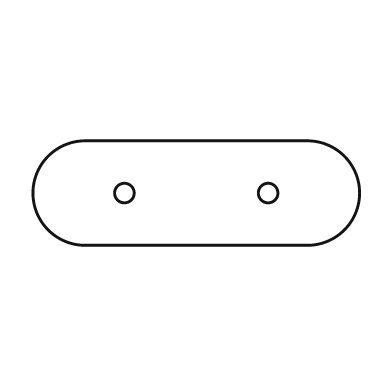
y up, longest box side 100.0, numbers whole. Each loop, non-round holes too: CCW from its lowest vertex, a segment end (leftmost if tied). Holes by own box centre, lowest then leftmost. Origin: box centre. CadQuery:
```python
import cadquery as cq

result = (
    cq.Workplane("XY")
    .moveTo(-34.0, -16.0)
    .lineTo(34.0, -16.0)
    .threePointArc((50.0, 0.0), (34.0, 16.0))
    .lineTo(-34.0, 16.0)
    .threePointArc((-50.0, 0.0), (-34.0, -16.0))
    .close()
    .moveTo(-22.0, 0.0)
    .circle(3.0)
    .moveTo(22.0, 0.0)
    .circle(3.0)
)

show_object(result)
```